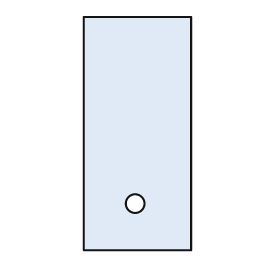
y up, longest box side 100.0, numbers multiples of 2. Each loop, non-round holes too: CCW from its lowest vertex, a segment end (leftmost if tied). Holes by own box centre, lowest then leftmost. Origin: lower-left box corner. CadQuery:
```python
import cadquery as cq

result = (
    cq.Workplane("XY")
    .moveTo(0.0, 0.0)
    .lineTo(46.0, 0.0)
    .lineTo(46.0, 100.0)
    .lineTo(0.0, 100.0)
    .close()
    .moveTo(22.0, 20.0)
    .circle(4.0)
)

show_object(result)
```